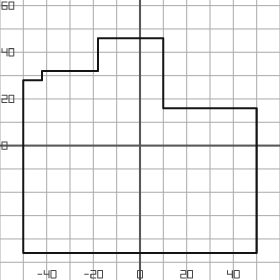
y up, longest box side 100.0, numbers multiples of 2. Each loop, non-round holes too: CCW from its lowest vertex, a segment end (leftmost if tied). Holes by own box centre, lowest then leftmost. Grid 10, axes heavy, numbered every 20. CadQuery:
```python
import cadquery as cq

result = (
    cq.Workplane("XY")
    .moveTo(-50.0, -46.0)
    .lineTo(50.0, -46.0)
    .lineTo(50.0, 16.0)
    .lineTo(10.0, 16.0)
    .lineTo(10.0, 46.0)
    .lineTo(-18.0, 46.0)
    .lineTo(-18.0, 32.0)
    .lineTo(-42.0, 32.0)
    .lineTo(-42.0, 28.0)
    .lineTo(-50.0, 28.0)
    .close()
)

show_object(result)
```